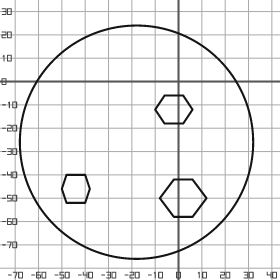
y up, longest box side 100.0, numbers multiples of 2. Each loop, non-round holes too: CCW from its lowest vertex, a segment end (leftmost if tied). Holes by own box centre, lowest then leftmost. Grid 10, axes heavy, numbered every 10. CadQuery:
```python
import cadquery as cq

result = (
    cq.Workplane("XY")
    .moveTo(-18.0, -26.0)
    .circle(50.0)
    .moveTo(-2.0, -58.0)
    .lineTo(6.0, -58.0)
    .lineTo(12.0, -50.0)
    .lineTo(6.0, -42.0)
    .lineTo(-2.0, -42.0)
    .lineTo(-8.0, -50.0)
    .close()
    .moveTo(-48.0, -52.0)
    .lineTo(-40.0, -52.0)
    .lineTo(-38.0, -46.0)
    .lineTo(-40.0, -40.0)
    .lineTo(-48.0, -40.0)
    .lineTo(-50.0, -46.0)
    .close()
    .moveTo(-6.0, -18.0)
    .lineTo(2.0, -18.0)
    .lineTo(6.0, -12.0)
    .lineTo(2.0, -6.0)
    .lineTo(-6.0, -6.0)
    .lineTo(-10.0, -12.0)
    .close()
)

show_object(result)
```